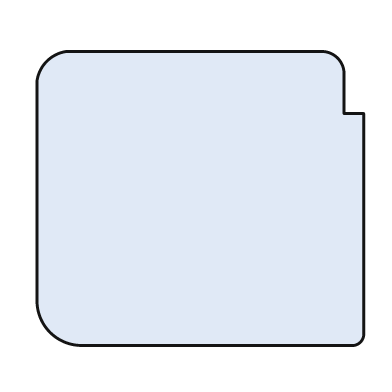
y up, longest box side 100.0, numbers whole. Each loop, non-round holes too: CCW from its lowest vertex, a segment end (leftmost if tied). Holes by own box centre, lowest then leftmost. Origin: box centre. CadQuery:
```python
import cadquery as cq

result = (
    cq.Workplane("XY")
    .moveTo(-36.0, -45.0)
    .lineTo(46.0, -45.0)
    .threePointArc((49.0, -44.0), (50.0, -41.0))
    .lineTo(50.0, 26.0)
    .lineTo(44.0, 26.0)
    .lineTo(44.0, 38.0)
    .threePointArc((42.0, 43.0), (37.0, 45.0))
    .lineTo(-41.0, 45.0)
    .threePointArc((-47.0, 42.0), (-50.0, 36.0))
    .lineTo(-50.0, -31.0)
    .threePointArc((-46.0, -41.0), (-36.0, -45.0))
    .close()
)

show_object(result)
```